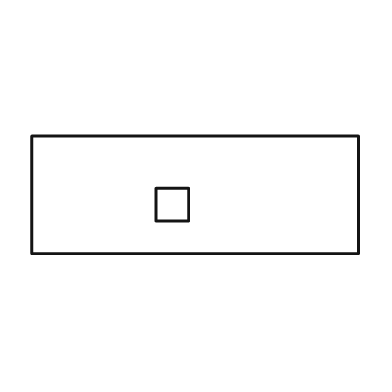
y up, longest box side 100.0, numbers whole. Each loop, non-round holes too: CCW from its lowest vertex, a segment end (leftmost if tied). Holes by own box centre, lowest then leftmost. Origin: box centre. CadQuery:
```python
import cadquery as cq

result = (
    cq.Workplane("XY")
    .moveTo(-50.0, -18.0)
    .lineTo(50.0, -18.0)
    .lineTo(50.0, 18.0)
    .lineTo(-50.0, 18.0)
    .close()
    .moveTo(-12.0, -8.0)
    .lineTo(-2.0, -8.0)
    .lineTo(-2.0, 2.0)
    .lineTo(-12.0, 2.0)
    .close()
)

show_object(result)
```